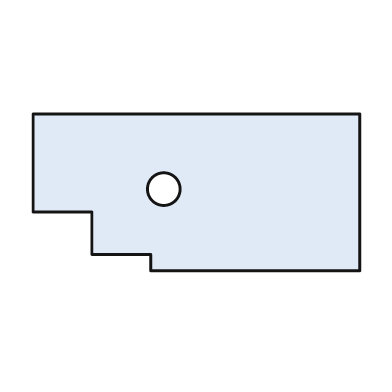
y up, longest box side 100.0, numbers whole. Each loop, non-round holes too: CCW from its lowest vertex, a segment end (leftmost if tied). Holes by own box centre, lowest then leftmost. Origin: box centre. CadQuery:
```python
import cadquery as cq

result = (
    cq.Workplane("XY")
    .moveTo(-14.0, -24.0)
    .lineTo(50.0, -24.0)
    .lineTo(50.0, 24.0)
    .lineTo(-50.0, 24.0)
    .lineTo(-50.0, -6.0)
    .lineTo(-32.0, -6.0)
    .lineTo(-32.0, -19.0)
    .lineTo(-14.0, -19.0)
    .close()
    .moveTo(-10.0, 1.0)
    .circle(5.0)
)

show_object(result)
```